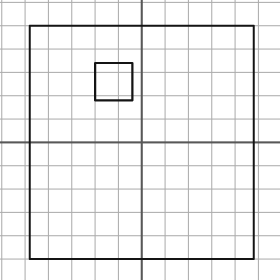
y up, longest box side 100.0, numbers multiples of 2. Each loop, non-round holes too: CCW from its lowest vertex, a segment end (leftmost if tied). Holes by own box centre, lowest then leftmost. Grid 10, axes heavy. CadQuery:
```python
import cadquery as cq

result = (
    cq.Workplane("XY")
    .moveTo(-48.0, -50.0)
    .lineTo(48.0, -50.0)
    .lineTo(48.0, 50.0)
    .lineTo(-48.0, 50.0)
    .close()
    .moveTo(-20.0, 18.0)
    .lineTo(-4.0, 18.0)
    .lineTo(-4.0, 34.0)
    .lineTo(-20.0, 34.0)
    .close()
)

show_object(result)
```